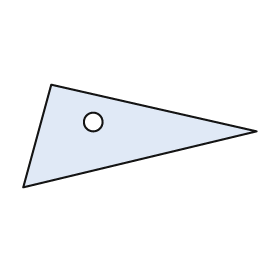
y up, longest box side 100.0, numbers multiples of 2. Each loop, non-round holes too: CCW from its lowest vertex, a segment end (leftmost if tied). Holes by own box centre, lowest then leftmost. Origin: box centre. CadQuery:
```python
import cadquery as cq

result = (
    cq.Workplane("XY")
    .moveTo(-50.0, -22.0)
    .lineTo(50.0, 2.0)
    .lineTo(-38.0, 22.0)
    .close()
    .moveTo(-20.0, 6.0)
    .circle(4.0)
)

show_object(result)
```